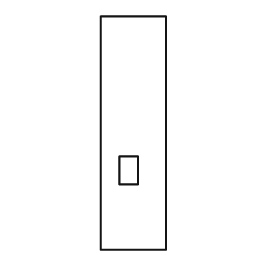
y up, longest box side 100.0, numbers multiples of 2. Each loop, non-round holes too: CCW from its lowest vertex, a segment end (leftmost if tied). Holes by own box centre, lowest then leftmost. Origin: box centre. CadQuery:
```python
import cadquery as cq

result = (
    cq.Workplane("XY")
    .moveTo(-14.0, -50.0)
    .lineTo(14.0, -50.0)
    .lineTo(14.0, 50.0)
    .lineTo(-14.0, 50.0)
    .close()
    .moveTo(-6.0, -22.0)
    .lineTo(2.0, -22.0)
    .lineTo(2.0, -10.0)
    .lineTo(-6.0, -10.0)
    .close()
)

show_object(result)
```